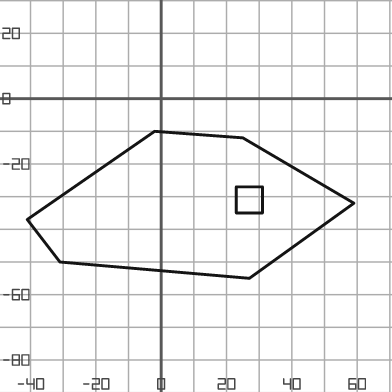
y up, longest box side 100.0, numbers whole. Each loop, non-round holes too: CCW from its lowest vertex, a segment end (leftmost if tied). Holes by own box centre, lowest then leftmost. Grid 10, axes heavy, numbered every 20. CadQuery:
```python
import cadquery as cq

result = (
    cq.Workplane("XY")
    .moveTo(27.0, -55.0)
    .lineTo(59.0, -32.0)
    .lineTo(25.0, -12.0)
    .lineTo(-2.0, -10.0)
    .lineTo(-41.0, -37.0)
    .lineTo(-31.0, -50.0)
    .close()
    .moveTo(23.0, -35.0)
    .lineTo(31.0, -35.0)
    .lineTo(31.0, -27.0)
    .lineTo(23.0, -27.0)
    .close()
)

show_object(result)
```